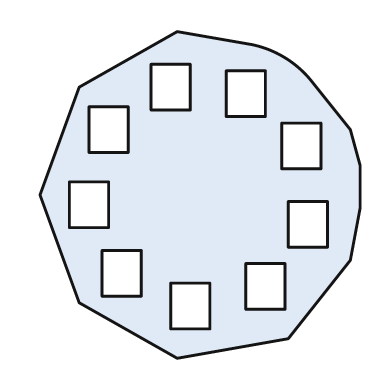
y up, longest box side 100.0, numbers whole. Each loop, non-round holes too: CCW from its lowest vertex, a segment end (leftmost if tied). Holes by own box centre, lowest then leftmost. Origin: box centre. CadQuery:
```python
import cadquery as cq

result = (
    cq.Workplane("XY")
    .moveTo(-7.0, -50.0)
    .lineTo(27.0, -44.0)
    .lineTo(46.0, -20.0)
    .lineTo(49.0, -4.0)
    .lineTo(49.0, 9.0)
    .lineTo(46.0, 20.0)
    .lineTo(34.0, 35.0)
    .threePointArc((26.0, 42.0), (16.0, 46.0))
    .lineTo(-7.0, 50.0)
    .lineTo(-37.0, 33.0)
    .lineTo(-49.0, 0.0)
    .lineTo(-37.0, -33.0)
    .close()
    .moveTo(-9.0, -41.0)
    .lineTo(3.0, -41.0)
    .lineTo(3.0, -27.0)
    .lineTo(-9.0, -27.0)
    .close()
    .moveTo(14.0, -35.0)
    .lineTo(26.0, -35.0)
    .lineTo(26.0, -21.0)
    .lineTo(14.0, -21.0)
    .close()
    .moveTo(-30.0, -31.0)
    .lineTo(-18.0, -31.0)
    .lineTo(-18.0, -17.0)
    .lineTo(-30.0, -17.0)
    .close()
    .moveTo(27.0, -16.0)
    .lineTo(39.0, -16.0)
    .lineTo(39.0, -2.0)
    .lineTo(27.0, -2.0)
    .close()
    .moveTo(-40.0, -10.0)
    .lineTo(-28.0, -10.0)
    .lineTo(-28.0, 4.0)
    .lineTo(-40.0, 4.0)
    .close()
    .moveTo(25.0, 8.0)
    .lineTo(37.0, 8.0)
    .lineTo(37.0, 22.0)
    .lineTo(25.0, 22.0)
    .close()
    .moveTo(-34.0, 13.0)
    .lineTo(-22.0, 13.0)
    .lineTo(-22.0, 27.0)
    .lineTo(-34.0, 27.0)
    .close()
    .moveTo(8.0, 24.0)
    .lineTo(20.0, 24.0)
    .lineTo(20.0, 38.0)
    .lineTo(8.0, 38.0)
    .close()
    .moveTo(-15.0, 26.0)
    .lineTo(-3.0, 26.0)
    .lineTo(-3.0, 40.0)
    .lineTo(-15.0, 40.0)
    .close()
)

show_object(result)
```